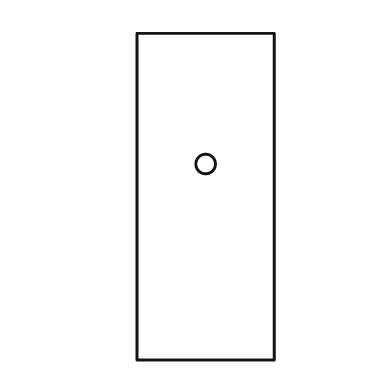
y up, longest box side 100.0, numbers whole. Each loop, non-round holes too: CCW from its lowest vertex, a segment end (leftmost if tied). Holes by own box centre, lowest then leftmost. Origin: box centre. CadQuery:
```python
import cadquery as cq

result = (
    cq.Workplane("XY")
    .moveTo(-21.0, -50.0)
    .lineTo(21.0, -50.0)
    .lineTo(21.0, 50.0)
    .lineTo(-21.0, 50.0)
    .close()
    .moveTo(0.0, 10.0)
    .circle(3.0)
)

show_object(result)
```